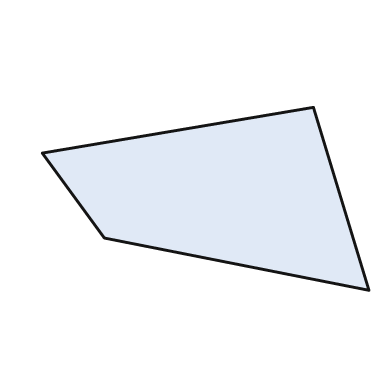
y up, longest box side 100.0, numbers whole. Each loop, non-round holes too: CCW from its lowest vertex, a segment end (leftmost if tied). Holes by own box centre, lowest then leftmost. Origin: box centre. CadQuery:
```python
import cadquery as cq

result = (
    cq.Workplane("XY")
    .moveTo(50.0, -28.0)
    .lineTo(33.0, 28.0)
    .lineTo(-50.0, 14.0)
    .lineTo(-31.0, -12.0)
    .close()
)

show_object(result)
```